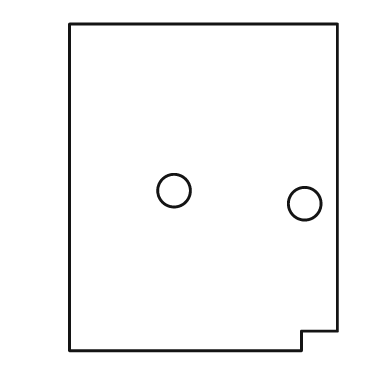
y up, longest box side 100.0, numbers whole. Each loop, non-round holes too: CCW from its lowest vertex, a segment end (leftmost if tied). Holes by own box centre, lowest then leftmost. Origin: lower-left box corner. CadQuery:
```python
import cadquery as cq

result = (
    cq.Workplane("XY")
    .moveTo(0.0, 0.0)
    .lineTo(71.0, 0.0)
    .lineTo(71.0, 6.0)
    .lineTo(82.0, 6.0)
    .lineTo(82.0, 100.0)
    .lineTo(0.0, 100.0)
    .close()
    .moveTo(72.0, 45.0)
    .circle(5.0)
    .moveTo(32.0, 49.0)
    .circle(5.0)
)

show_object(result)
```